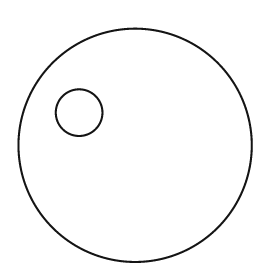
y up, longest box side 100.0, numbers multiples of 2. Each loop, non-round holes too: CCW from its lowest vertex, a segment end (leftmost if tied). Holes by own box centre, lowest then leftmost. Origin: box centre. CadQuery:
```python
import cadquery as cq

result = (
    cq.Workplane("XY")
    .moveTo(0.0, 0.0)
    .circle(50.0)
    .moveTo(-24.0, 14.0)
    .circle(10.0)
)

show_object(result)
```